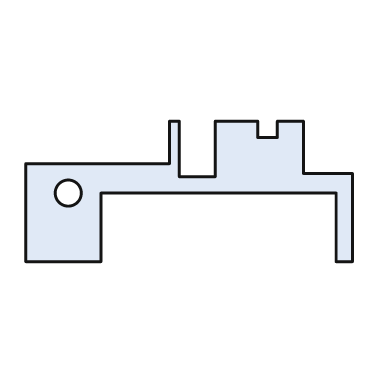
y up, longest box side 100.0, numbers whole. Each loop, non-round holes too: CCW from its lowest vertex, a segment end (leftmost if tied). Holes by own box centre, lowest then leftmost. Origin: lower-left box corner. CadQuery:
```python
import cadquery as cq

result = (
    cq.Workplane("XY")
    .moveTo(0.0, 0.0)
    .lineTo(23.0, 0.0)
    .lineTo(23.0, 21.0)
    .lineTo(95.0, 21.0)
    .lineTo(95.0, 0.0)
    .lineTo(100.0, 0.0)
    .lineTo(100.0, 27.0)
    .lineTo(85.0, 27.0)
    .lineTo(85.0, 43.0)
    .lineTo(77.0, 43.0)
    .lineTo(77.0, 38.0)
    .lineTo(71.0, 38.0)
    .lineTo(71.0, 43.0)
    .lineTo(58.0, 43.0)
    .lineTo(58.0, 26.0)
    .lineTo(47.0, 26.0)
    .lineTo(47.0, 43.0)
    .lineTo(44.0, 43.0)
    .lineTo(44.0, 30.0)
    .lineTo(0.0, 30.0)
    .close()
    .moveTo(13.0, 21.0)
    .circle(4.0)
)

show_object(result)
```